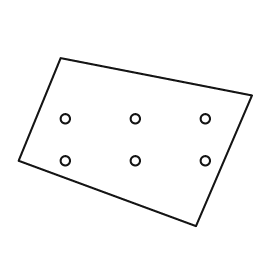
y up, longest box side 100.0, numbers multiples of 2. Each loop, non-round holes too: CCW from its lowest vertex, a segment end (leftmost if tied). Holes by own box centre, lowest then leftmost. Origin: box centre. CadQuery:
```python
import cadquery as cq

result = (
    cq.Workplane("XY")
    .moveTo(26.0, -36.0)
    .lineTo(50.0, 20.0)
    .lineTo(-32.0, 36.0)
    .lineTo(-50.0, -8.0)
    .close()
    .moveTo(-30.0, -8.0)
    .circle(2.0)
    .moveTo(0.0, -8.0)
    .circle(2.0)
    .moveTo(30.0, -8.0)
    .circle(2.0)
    .moveTo(-30.0, 10.0)
    .circle(2.0)
    .moveTo(0.0, 10.0)
    .circle(2.0)
    .moveTo(30.0, 10.0)
    .circle(2.0)
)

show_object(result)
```